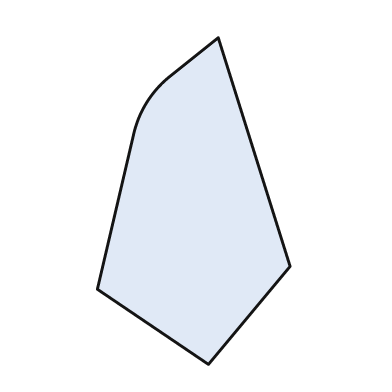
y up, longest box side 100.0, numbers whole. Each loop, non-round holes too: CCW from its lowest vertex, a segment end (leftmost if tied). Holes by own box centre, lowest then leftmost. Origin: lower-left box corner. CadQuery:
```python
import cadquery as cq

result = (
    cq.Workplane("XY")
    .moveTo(34.0, 0.0)
    .lineTo(59.0, 30.0)
    .lineTo(37.0, 100.0)
    .lineTo(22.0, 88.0)
    .threePointArc((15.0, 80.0), (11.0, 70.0))
    .lineTo(0.0, 23.0)
    .close()
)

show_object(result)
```